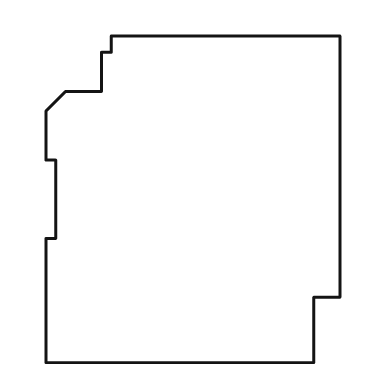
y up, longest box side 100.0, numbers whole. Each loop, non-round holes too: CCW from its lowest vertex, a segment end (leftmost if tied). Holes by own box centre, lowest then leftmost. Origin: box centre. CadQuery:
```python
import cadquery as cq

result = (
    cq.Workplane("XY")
    .moveTo(-45.0, -50.0)
    .lineTo(37.0, -50.0)
    .lineTo(37.0, -30.0)
    .lineTo(45.0, -30.0)
    .lineTo(45.0, 50.0)
    .lineTo(-25.0, 50.0)
    .lineTo(-25.0, 45.0)
    .lineTo(-28.0, 45.0)
    .lineTo(-28.0, 33.0)
    .lineTo(-39.0, 33.0)
    .lineTo(-45.0, 27.0)
    .lineTo(-45.0, 12.0)
    .lineTo(-42.0, 12.0)
    .lineTo(-42.0, -12.0)
    .lineTo(-45.0, -12.0)
    .close()
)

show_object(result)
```